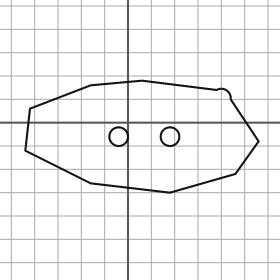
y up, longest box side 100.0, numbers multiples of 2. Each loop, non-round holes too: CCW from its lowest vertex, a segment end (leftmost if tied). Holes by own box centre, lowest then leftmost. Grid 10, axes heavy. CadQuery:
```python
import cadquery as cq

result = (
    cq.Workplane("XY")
    .moveTo(18.0, -30.0)
    .lineTo(46.0, -22.0)
    .lineTo(56.0, -8.0)
    .lineTo(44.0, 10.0)
    .threePointArc((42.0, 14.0), (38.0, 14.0))
    .lineTo(6.0, 18.0)
    .lineTo(-16.0, 16.0)
    .lineTo(-42.0, 6.0)
    .lineTo(-44.0, -12.0)
    .lineTo(-16.0, -26.0)
    .close()
    .moveTo(-4.0, -6.0)
    .circle(4.0)
    .moveTo(18.0, -6.0)
    .circle(4.0)
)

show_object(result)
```